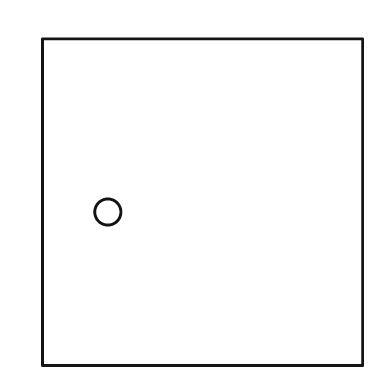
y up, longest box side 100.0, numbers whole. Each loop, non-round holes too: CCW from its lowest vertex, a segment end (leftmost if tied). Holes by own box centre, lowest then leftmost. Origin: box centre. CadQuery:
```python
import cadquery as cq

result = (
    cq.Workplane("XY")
    .moveTo(-49.0, -50.0)
    .lineTo(49.0, -50.0)
    .lineTo(49.0, 50.0)
    .lineTo(-49.0, 50.0)
    .close()
    .moveTo(-29.0, -3.0)
    .circle(4.0)
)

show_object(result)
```